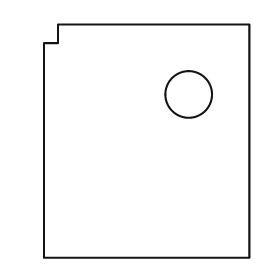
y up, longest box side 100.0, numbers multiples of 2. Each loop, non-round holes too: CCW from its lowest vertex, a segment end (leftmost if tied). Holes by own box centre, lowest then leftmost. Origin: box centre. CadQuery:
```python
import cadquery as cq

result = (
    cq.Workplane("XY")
    .moveTo(-44.0, -50.0)
    .lineTo(44.0, -50.0)
    .lineTo(44.0, 50.0)
    .lineTo(-38.0, 50.0)
    .lineTo(-38.0, 42.0)
    .lineTo(-44.0, 42.0)
    .close()
    .moveTo(18.0, 20.0)
    .circle(10.0)
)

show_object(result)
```